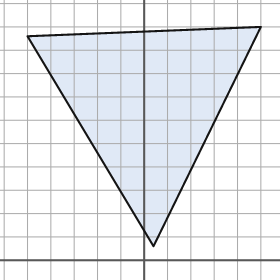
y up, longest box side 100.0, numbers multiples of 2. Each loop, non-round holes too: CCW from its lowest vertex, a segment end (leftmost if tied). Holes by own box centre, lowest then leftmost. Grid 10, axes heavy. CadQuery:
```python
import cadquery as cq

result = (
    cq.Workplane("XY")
    .moveTo(4.0, 6.0)
    .lineTo(50.0, 100.0)
    .lineTo(-50.0, 96.0)
    .close()
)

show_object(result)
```